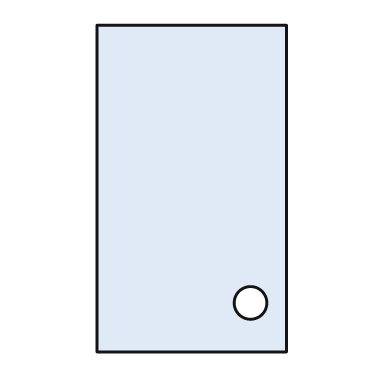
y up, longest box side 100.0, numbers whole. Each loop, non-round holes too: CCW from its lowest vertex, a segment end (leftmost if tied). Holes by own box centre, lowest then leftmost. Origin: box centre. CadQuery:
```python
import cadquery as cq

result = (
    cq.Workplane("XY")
    .moveTo(-29.0, -50.0)
    .lineTo(29.0, -50.0)
    .lineTo(29.0, 50.0)
    .lineTo(-29.0, 50.0)
    .close()
    .moveTo(18.0, -35.0)
    .circle(5.0)
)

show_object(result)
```